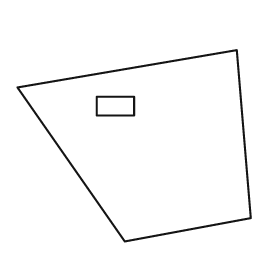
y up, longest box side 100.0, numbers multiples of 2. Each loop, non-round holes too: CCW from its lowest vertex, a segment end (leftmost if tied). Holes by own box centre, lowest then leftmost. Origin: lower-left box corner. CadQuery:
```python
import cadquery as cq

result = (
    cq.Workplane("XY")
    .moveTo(46.0, 0.0)
    .lineTo(100.0, 10.0)
    .lineTo(94.0, 82.0)
    .lineTo(0.0, 66.0)
    .close()
    .moveTo(34.0, 54.0)
    .lineTo(50.0, 54.0)
    .lineTo(50.0, 62.0)
    .lineTo(34.0, 62.0)
    .close()
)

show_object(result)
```